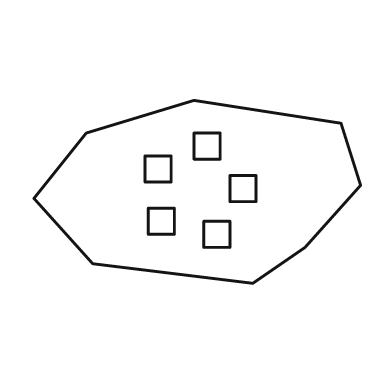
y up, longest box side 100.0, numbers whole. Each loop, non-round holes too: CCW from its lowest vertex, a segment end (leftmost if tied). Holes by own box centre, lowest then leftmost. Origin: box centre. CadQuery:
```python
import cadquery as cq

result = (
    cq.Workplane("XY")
    .moveTo(17.0, -28.0)
    .lineTo(33.0, -17.0)
    .lineTo(50.0, 2.0)
    .lineTo(44.0, 21.0)
    .lineTo(-1.0, 28.0)
    .lineTo(-34.0, 18.0)
    .lineTo(-50.0, -2.0)
    .lineTo(-32.0, -22.0)
    .close()
    .moveTo(2.0, -17.0)
    .lineTo(10.0, -17.0)
    .lineTo(10.0, -9.0)
    .lineTo(2.0, -9.0)
    .close()
    .moveTo(-15.0, -13.0)
    .lineTo(-7.0, -13.0)
    .lineTo(-7.0, -5.0)
    .lineTo(-15.0, -5.0)
    .close()
    .moveTo(10.0, -3.0)
    .lineTo(18.0, -3.0)
    .lineTo(18.0, 5.0)
    .lineTo(10.0, 5.0)
    .close()
    .moveTo(-16.0, 3.0)
    .lineTo(-8.0, 3.0)
    .lineTo(-8.0, 11.0)
    .lineTo(-16.0, 11.0)
    .close()
    .moveTo(-1.0, 10.0)
    .lineTo(7.0, 10.0)
    .lineTo(7.0, 18.0)
    .lineTo(-1.0, 18.0)
    .close()
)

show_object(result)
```